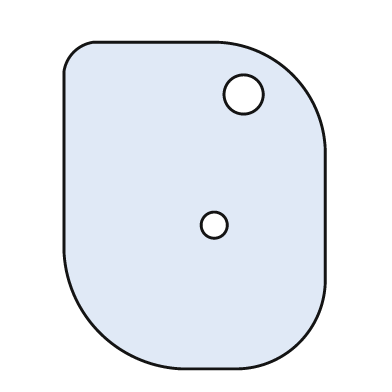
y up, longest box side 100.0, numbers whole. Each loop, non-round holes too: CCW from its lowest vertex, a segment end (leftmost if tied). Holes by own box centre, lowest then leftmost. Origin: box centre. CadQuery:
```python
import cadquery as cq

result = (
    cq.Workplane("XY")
    .moveTo(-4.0, -50.0)
    .lineTo(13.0, -50.0)
    .threePointArc((32.0, -42.0), (40.0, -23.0))
    .lineTo(40.0, 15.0)
    .threePointArc((30.0, 40.0), (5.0, 50.0))
    .lineTo(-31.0, 50.0)
    .threePointArc((-37.0, 47.0), (-40.0, 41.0))
    .lineTo(-40.0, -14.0)
    .threePointArc((-29.0, -39.0), (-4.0, -50.0))
    .close()
    .moveTo(6.0, -6.0)
    .circle(4.0)
    .moveTo(15.0, 34.0)
    .circle(6.0)
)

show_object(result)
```